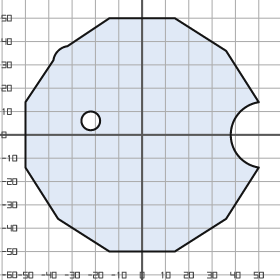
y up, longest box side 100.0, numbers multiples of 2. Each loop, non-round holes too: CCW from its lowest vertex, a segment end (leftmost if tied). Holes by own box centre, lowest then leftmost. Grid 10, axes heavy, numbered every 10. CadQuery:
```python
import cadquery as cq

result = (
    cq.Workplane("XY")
    .moveTo(-14.0, -50.0)
    .lineTo(14.0, -50.0)
    .lineTo(36.0, -36.0)
    .lineTo(50.0, -14.0)
    .threePointArc((38.0, 0.0), (50.0, 14.0))
    .lineTo(36.0, 36.0)
    .lineTo(14.0, 50.0)
    .lineTo(-14.0, 50.0)
    .lineTo(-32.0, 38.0)
    .threePointArc((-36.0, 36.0), (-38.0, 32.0))
    .lineTo(-50.0, 14.0)
    .lineTo(-50.0, -14.0)
    .lineTo(-36.0, -36.0)
    .close()
    .moveTo(-22.0, 6.0)
    .circle(4.0)
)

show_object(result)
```